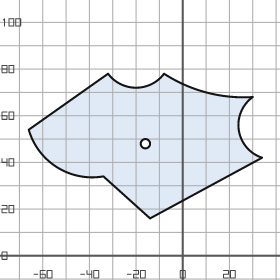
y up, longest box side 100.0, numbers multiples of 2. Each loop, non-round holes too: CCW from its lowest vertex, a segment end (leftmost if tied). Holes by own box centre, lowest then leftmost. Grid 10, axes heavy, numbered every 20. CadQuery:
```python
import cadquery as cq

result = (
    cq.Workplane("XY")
    .moveTo(-14.0, 16.0)
    .lineTo(34.0, 42.0)
    .threePointArc((24.0, 54.0), (30.0, 68.0))
    .threePointArc((10.0, 70.0), (-8.0, 78.0))
    .threePointArc((-20.0, 72.0), (-32.0, 78.0))
    .lineTo(-66.0, 54.0)
    .threePointArc((-54.0, 38.0), (-34.0, 34.0))
    .close()
    .moveTo(-16.0, 48.0)
    .circle(2.0)
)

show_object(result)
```